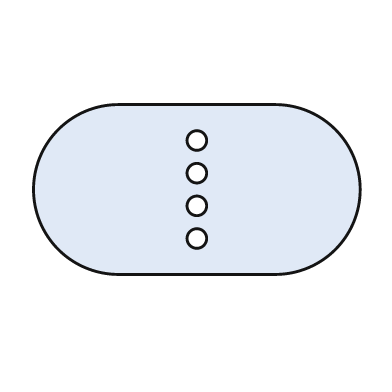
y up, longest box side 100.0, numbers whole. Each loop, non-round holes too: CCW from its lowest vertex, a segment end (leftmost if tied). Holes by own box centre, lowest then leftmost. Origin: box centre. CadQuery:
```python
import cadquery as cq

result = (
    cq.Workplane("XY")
    .moveTo(-24.0, -26.0)
    .lineTo(24.0, -26.0)
    .threePointArc((50.0, 0.0), (24.0, 26.0))
    .lineTo(-24.0, 26.0)
    .threePointArc((-50.0, 0.0), (-24.0, -26.0))
    .close()
    .moveTo(0.0, -15.0)
    .circle(3.0)
    .moveTo(0.0, -5.0)
    .circle(3.0)
    .moveTo(0.0, 5.0)
    .circle(3.0)
    .moveTo(0.0, 15.0)
    .circle(3.0)
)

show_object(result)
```